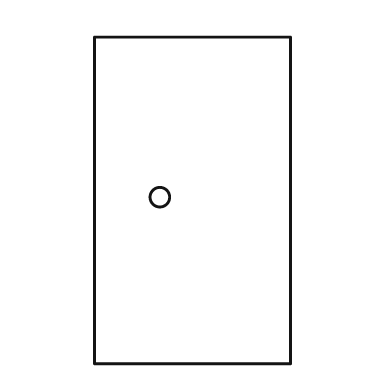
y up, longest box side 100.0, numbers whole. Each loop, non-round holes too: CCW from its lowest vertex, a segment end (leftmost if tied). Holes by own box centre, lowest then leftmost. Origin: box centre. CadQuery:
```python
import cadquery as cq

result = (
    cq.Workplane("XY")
    .moveTo(-30.0, -50.0)
    .lineTo(30.0, -50.0)
    .lineTo(30.0, 50.0)
    .lineTo(-30.0, 50.0)
    .close()
    .moveTo(-10.0, 1.0)
    .circle(3.0)
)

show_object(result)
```